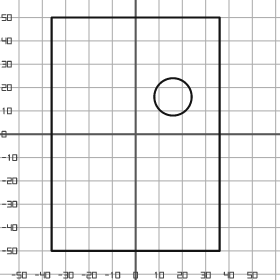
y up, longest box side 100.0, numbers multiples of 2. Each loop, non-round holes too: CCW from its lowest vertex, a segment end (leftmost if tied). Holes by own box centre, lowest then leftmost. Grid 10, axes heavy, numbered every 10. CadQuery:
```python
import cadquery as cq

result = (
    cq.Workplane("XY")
    .moveTo(-36.0, -50.0)
    .lineTo(36.0, -50.0)
    .lineTo(36.0, 50.0)
    .lineTo(-36.0, 50.0)
    .close()
    .moveTo(16.0, 16.0)
    .circle(8.0)
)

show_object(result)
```